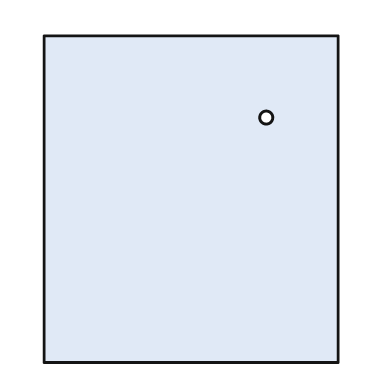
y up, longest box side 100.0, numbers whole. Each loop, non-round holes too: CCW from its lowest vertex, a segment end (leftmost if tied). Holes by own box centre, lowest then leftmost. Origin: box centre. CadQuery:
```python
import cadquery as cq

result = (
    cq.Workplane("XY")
    .moveTo(-45.0, -50.0)
    .lineTo(45.0, -50.0)
    .lineTo(45.0, 50.0)
    .lineTo(-45.0, 50.0)
    .close()
    .moveTo(23.0, 25.0)
    .circle(2.0)
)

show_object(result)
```